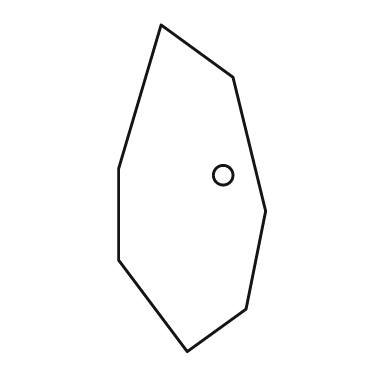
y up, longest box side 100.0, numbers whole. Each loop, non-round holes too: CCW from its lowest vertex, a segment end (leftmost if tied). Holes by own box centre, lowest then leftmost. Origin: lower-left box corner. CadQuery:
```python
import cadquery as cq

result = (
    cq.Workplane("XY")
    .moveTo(21.0, 0.0)
    .lineTo(39.0, 13.0)
    .lineTo(45.0, 43.0)
    .lineTo(35.0, 84.0)
    .lineTo(13.0, 100.0)
    .lineTo(0.0, 56.0)
    .lineTo(0.0, 28.0)
    .close()
    .moveTo(32.0, 54.0)
    .circle(3.0)
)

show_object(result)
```